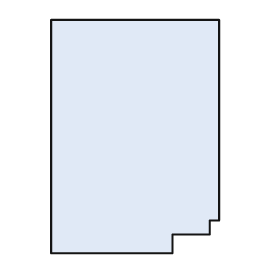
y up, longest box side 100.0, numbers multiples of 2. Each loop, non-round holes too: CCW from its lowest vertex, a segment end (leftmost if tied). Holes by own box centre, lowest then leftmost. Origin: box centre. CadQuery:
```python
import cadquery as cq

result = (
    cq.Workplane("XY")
    .moveTo(-36.0, -50.0)
    .lineTo(16.0, -50.0)
    .lineTo(16.0, -42.0)
    .lineTo(32.0, -42.0)
    .lineTo(32.0, -36.0)
    .lineTo(36.0, -36.0)
    .lineTo(36.0, 50.0)
    .lineTo(-36.0, 50.0)
    .close()
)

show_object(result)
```